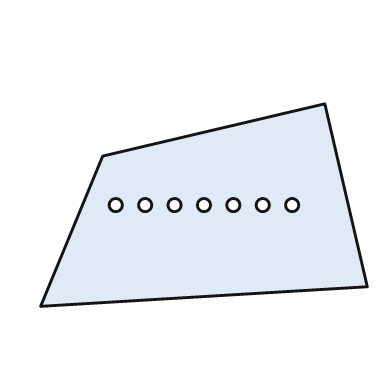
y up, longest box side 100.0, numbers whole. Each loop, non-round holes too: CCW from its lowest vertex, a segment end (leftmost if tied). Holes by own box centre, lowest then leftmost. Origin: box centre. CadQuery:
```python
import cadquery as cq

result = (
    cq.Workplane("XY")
    .moveTo(-50.0, -31.0)
    .lineTo(50.0, -25.0)
    .lineTo(37.0, 31.0)
    .lineTo(-31.0, 15.0)
    .close()
    .moveTo(-27.0, 0.0)
    .circle(2.0)
    .moveTo(-18.0, 0.0)
    .circle(2.0)
    .moveTo(-9.0, 0.0)
    .circle(2.0)
    .moveTo(0.0, 0.0)
    .circle(2.0)
    .moveTo(9.0, 0.0)
    .circle(2.0)
    .moveTo(18.0, 0.0)
    .circle(2.0)
    .moveTo(27.0, 0.0)
    .circle(2.0)
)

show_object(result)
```